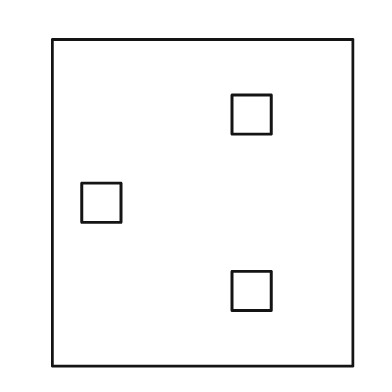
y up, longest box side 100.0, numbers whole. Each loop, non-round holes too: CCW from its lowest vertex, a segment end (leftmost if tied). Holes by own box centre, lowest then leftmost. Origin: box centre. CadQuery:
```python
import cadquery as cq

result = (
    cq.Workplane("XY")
    .moveTo(-46.0, -50.0)
    .lineTo(46.0, -50.0)
    .lineTo(46.0, 50.0)
    .lineTo(-46.0, 50.0)
    .close()
    .moveTo(9.0, -33.0)
    .lineTo(21.0, -33.0)
    .lineTo(21.0, -21.0)
    .lineTo(9.0, -21.0)
    .close()
    .moveTo(-37.0, -6.0)
    .lineTo(-25.0, -6.0)
    .lineTo(-25.0, 6.0)
    .lineTo(-37.0, 6.0)
    .close()
    .moveTo(9.0, 21.0)
    .lineTo(21.0, 21.0)
    .lineTo(21.0, 33.0)
    .lineTo(9.0, 33.0)
    .close()
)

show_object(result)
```